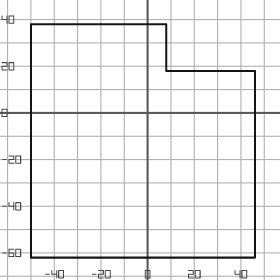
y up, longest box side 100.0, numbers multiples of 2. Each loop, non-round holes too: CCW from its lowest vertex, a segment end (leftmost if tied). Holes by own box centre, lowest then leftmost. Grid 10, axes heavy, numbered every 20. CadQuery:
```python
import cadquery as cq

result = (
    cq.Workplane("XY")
    .moveTo(-50.0, -62.0)
    .lineTo(46.0, -62.0)
    .lineTo(46.0, 18.0)
    .lineTo(8.0, 18.0)
    .lineTo(8.0, 38.0)
    .lineTo(-50.0, 38.0)
    .close()
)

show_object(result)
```